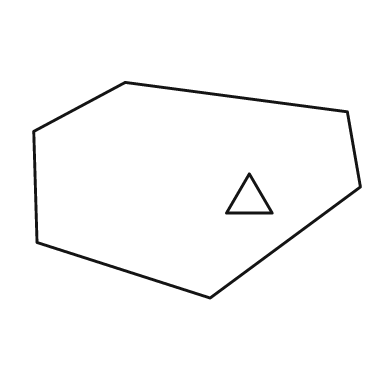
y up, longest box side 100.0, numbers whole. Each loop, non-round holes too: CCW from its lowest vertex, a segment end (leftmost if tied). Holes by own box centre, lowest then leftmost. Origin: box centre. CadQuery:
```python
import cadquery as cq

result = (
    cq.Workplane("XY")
    .moveTo(4.0, -33.0)
    .lineTo(50.0, 1.0)
    .lineTo(46.0, 24.0)
    .lineTo(-22.0, 33.0)
    .lineTo(-50.0, 18.0)
    .lineTo(-49.0, -16.0)
    .close()
    .moveTo(9.0, -7.0)
    .lineTo(23.0, -7.0)
    .lineTo(16.0, 5.0)
    .close()
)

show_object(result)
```